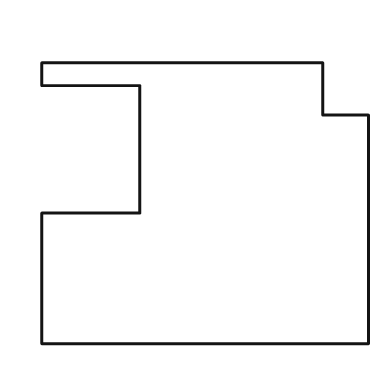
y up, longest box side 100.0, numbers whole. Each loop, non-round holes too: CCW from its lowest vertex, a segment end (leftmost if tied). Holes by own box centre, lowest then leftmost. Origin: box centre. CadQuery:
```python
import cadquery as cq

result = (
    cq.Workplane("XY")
    .moveTo(-50.0, -43.0)
    .lineTo(50.0, -43.0)
    .lineTo(50.0, 27.0)
    .lineTo(36.0, 27.0)
    .lineTo(36.0, 43.0)
    .lineTo(-50.0, 43.0)
    .lineTo(-50.0, 36.0)
    .lineTo(-20.0, 36.0)
    .lineTo(-20.0, -3.0)
    .lineTo(-50.0, -3.0)
    .close()
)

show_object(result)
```